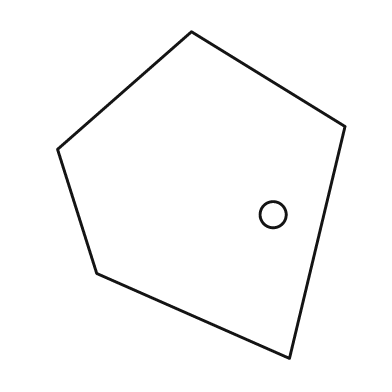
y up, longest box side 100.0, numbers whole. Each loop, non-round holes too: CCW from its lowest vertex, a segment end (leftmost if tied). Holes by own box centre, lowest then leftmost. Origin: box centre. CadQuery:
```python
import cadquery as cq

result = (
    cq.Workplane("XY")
    .moveTo(27.0, -50.0)
    .lineTo(44.0, 21.0)
    .lineTo(-3.0, 50.0)
    .lineTo(-44.0, 14.0)
    .lineTo(-32.0, -24.0)
    .close()
    .moveTo(22.0, -6.0)
    .circle(4.0)
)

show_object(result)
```